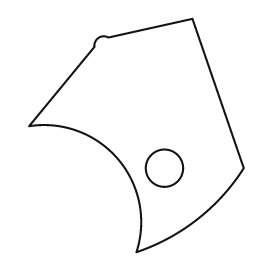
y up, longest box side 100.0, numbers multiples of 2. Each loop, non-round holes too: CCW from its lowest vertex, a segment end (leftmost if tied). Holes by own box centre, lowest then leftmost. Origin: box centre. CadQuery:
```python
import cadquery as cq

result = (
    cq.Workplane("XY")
    .moveTo(0.0, -50.0)
    .threePointArc((26.0, -36.0), (46.0, -14.0))
    .lineTo(24.0, 50.0)
    .lineTo(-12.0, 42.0)
    .threePointArc((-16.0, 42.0), (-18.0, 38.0))
    .lineTo(-46.0, 4.0)
    .threePointArc((-8.0, -10.0), (0.0, -50.0))
    .close()
    .moveTo(12.0, -14.0)
    .circle(8.0)
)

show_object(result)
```